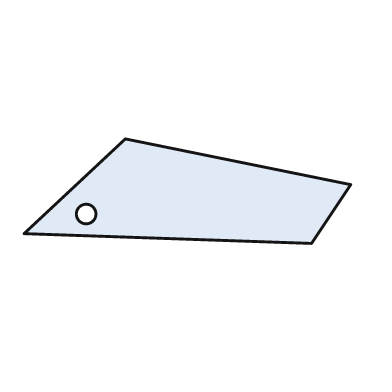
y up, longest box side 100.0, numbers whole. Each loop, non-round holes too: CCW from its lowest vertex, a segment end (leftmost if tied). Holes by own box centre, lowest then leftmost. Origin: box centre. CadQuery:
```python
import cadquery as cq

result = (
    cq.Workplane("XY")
    .moveTo(38.0, -16.0)
    .lineTo(50.0, 2.0)
    .lineTo(-19.0, 16.0)
    .lineTo(-50.0, -13.0)
    .close()
    .moveTo(-31.0, -7.0)
    .circle(3.0)
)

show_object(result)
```